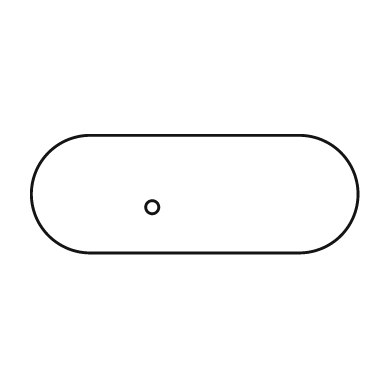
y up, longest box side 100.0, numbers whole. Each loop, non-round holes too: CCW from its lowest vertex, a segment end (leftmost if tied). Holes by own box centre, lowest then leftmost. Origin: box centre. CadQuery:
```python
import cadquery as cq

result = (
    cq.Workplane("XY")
    .moveTo(-32.0, -18.0)
    .lineTo(32.0, -18.0)
    .threePointArc((50.0, 0.0), (32.0, 18.0))
    .lineTo(-32.0, 18.0)
    .threePointArc((-50.0, 0.0), (-32.0, -18.0))
    .close()
    .moveTo(-13.0, -4.0)
    .circle(2.0)
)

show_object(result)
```